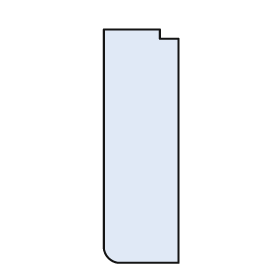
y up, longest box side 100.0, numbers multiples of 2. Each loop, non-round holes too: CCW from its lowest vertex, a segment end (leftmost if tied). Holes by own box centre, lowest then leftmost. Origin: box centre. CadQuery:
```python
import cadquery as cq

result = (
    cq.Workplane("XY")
    .moveTo(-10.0, -50.0)
    .lineTo(16.0, -50.0)
    .lineTo(16.0, 46.0)
    .lineTo(8.0, 46.0)
    .lineTo(8.0, 50.0)
    .lineTo(-16.0, 50.0)
    .lineTo(-16.0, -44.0)
    .threePointArc((-14.0, -48.0), (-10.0, -50.0))
    .close()
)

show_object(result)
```